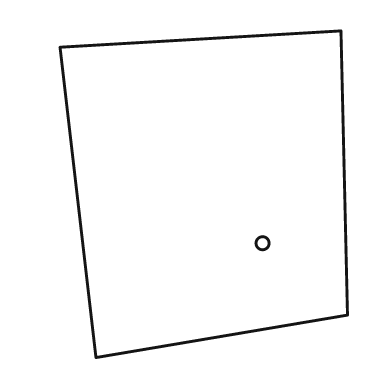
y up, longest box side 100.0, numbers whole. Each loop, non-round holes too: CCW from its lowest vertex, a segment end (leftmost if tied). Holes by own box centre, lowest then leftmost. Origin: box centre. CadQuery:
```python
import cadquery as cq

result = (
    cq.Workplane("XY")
    .moveTo(-33.0, -50.0)
    .lineTo(44.0, -37.0)
    .lineTo(42.0, 50.0)
    .lineTo(-44.0, 45.0)
    .close()
    .moveTo(18.0, -15.0)
    .circle(2.0)
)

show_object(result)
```